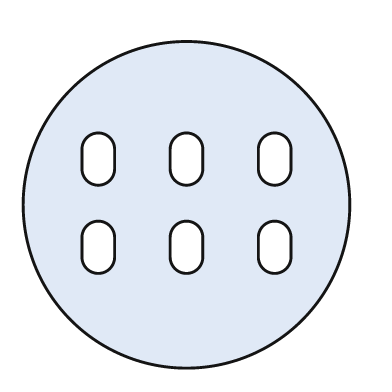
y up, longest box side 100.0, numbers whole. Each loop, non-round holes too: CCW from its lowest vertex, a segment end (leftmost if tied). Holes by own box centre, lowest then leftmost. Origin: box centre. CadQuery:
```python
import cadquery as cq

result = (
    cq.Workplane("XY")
    .moveTo(0.0, 0.0)
    .circle(50.0)
    .moveTo(-32.0, -16.0)
    .threePointArc((-27.0, -21.0), (-22.0, -16.0))
    .lineTo(-22.0, -10.0)
    .threePointArc((-27.0, -5.0), (-32.0, -10.0))
    .close()
    .moveTo(-5.0, -16.0)
    .threePointArc((0.0, -21.0), (5.0, -16.0))
    .lineTo(5.0, -10.0)
    .threePointArc((0.0, -5.0), (-5.0, -10.0))
    .close()
    .moveTo(22.0, -16.0)
    .threePointArc((27.0, -21.0), (32.0, -16.0))
    .lineTo(32.0, -10.0)
    .threePointArc((27.0, -5.0), (22.0, -10.0))
    .close()
    .moveTo(-32.0, 11.0)
    .threePointArc((-27.0, 6.0), (-22.0, 11.0))
    .lineTo(-22.0, 17.0)
    .threePointArc((-27.0, 22.0), (-32.0, 17.0))
    .close()
    .moveTo(-5.0, 11.0)
    .threePointArc((0.0, 6.0), (5.0, 11.0))
    .lineTo(5.0, 17.0)
    .threePointArc((0.0, 22.0), (-5.0, 17.0))
    .close()
    .moveTo(22.0, 11.0)
    .threePointArc((27.0, 6.0), (32.0, 11.0))
    .lineTo(32.0, 17.0)
    .threePointArc((27.0, 22.0), (22.0, 17.0))
    .close()
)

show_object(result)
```